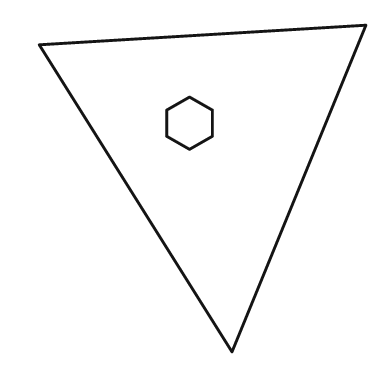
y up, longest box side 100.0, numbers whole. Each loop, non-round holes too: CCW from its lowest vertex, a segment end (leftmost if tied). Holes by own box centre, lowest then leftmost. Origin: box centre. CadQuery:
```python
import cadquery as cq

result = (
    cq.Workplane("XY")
    .moveTo(9.0, -50.0)
    .lineTo(50.0, 50.0)
    .lineTo(-50.0, 44.0)
    .close()
    .moveTo(-4.0, 12.0)
    .lineTo(3.0, 16.0)
    .lineTo(3.0, 24.0)
    .lineTo(-4.0, 28.0)
    .lineTo(-11.0, 24.0)
    .lineTo(-11.0, 16.0)
    .close()
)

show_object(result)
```